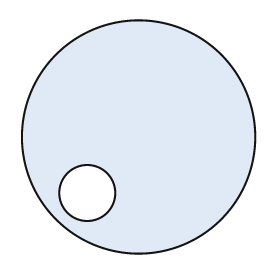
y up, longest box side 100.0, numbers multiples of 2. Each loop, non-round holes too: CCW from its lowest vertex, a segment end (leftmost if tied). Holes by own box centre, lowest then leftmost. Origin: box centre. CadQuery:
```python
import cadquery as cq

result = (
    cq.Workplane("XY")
    .moveTo(0.0, 0.0)
    .circle(50.0)
    .moveTo(-22.0, -24.0)
    .circle(12.0)
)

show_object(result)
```